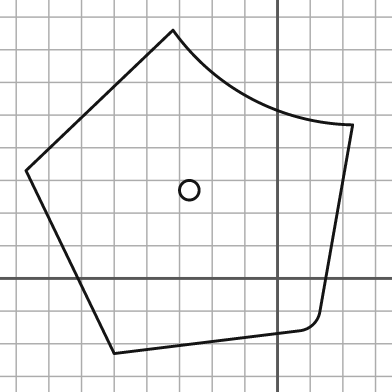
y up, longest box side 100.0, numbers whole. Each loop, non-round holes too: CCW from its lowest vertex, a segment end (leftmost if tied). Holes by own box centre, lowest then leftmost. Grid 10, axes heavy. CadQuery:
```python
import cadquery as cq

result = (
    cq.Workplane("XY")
    .moveTo(-50.0, -23.0)
    .lineTo(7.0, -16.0)
    .threePointArc((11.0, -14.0), (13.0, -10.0))
    .lineTo(23.0, 47.0)
    .threePointArc((-8.0, 55.0), (-32.0, 76.0))
    .lineTo(-77.0, 33.0)
    .close()
    .moveTo(-27.0, 27.0)
    .circle(3.0)
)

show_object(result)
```